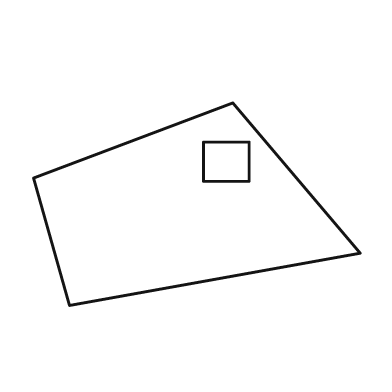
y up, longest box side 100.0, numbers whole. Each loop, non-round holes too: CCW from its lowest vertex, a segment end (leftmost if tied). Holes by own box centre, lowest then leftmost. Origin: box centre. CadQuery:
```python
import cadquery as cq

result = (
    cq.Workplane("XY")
    .moveTo(-39.0, -31.0)
    .lineTo(50.0, -15.0)
    .lineTo(11.0, 31.0)
    .lineTo(-50.0, 8.0)
    .close()
    .moveTo(2.0, 7.0)
    .lineTo(16.0, 7.0)
    .lineTo(16.0, 19.0)
    .lineTo(2.0, 19.0)
    .close()
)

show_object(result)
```